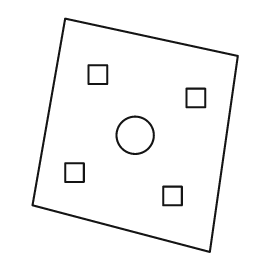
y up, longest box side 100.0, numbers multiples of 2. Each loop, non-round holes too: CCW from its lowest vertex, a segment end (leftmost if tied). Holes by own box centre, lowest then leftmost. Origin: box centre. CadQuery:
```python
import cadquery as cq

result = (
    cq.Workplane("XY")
    .moveTo(32.0, -50.0)
    .lineTo(44.0, 34.0)
    .lineTo(-30.0, 50.0)
    .lineTo(-44.0, -30.0)
    .close()
    .moveTo(12.0, -30.0)
    .lineTo(20.0, -30.0)
    .lineTo(20.0, -22.0)
    .lineTo(12.0, -22.0)
    .close()
    .moveTo(-30.0, -20.0)
    .lineTo(-22.0, -20.0)
    .lineTo(-22.0, -12.0)
    .lineTo(-30.0, -12.0)
    .close()
    .moveTo(0.0, 0.0)
    .circle(8.0)
    .moveTo(22.0, 12.0)
    .lineTo(30.0, 12.0)
    .lineTo(30.0, 20.0)
    .lineTo(22.0, 20.0)
    .close()
    .moveTo(-20.0, 22.0)
    .lineTo(-12.0, 22.0)
    .lineTo(-12.0, 30.0)
    .lineTo(-20.0, 30.0)
    .close()
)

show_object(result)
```